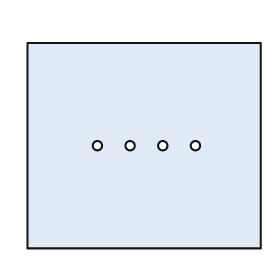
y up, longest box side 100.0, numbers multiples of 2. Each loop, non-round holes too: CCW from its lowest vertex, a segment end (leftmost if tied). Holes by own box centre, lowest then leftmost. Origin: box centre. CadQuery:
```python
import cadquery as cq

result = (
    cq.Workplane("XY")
    .moveTo(-50.0, -44.0)
    .lineTo(50.0, -44.0)
    .lineTo(50.0, 44.0)
    .lineTo(-50.0, 44.0)
    .close()
    .moveTo(-20.0, 0.0)
    .circle(2.0)
    .moveTo(-6.0, 0.0)
    .circle(2.0)
    .moveTo(8.0, 0.0)
    .circle(2.0)
    .moveTo(22.0, 0.0)
    .circle(2.0)
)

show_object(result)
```